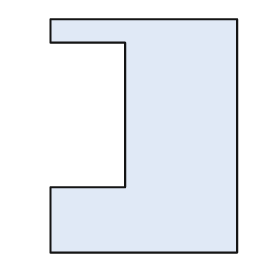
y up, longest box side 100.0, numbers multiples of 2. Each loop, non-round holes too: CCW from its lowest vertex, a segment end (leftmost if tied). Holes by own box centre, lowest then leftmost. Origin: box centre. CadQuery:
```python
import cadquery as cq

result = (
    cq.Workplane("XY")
    .moveTo(-40.0, -50.0)
    .lineTo(40.0, -50.0)
    .lineTo(40.0, 50.0)
    .lineTo(-40.0, 50.0)
    .lineTo(-40.0, 40.0)
    .lineTo(-8.0, 40.0)
    .lineTo(-8.0, -22.0)
    .lineTo(-40.0, -22.0)
    .close()
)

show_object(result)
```